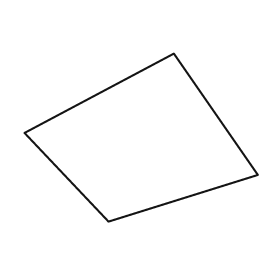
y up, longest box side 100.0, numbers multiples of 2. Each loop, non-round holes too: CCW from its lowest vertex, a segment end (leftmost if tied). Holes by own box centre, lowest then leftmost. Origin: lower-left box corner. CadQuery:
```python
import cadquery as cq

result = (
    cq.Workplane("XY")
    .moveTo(36.0, 0.0)
    .lineTo(100.0, 20.0)
    .lineTo(64.0, 72.0)
    .lineTo(0.0, 38.0)
    .close()
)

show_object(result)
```